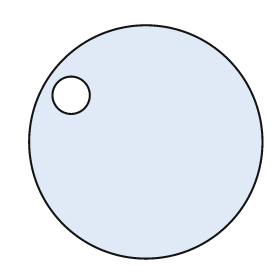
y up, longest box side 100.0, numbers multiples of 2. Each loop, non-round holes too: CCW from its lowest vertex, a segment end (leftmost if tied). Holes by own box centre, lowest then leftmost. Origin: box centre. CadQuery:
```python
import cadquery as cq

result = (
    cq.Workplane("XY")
    .moveTo(0.0, 0.0)
    .circle(50.0)
    .moveTo(-32.0, 20.0)
    .circle(8.0)
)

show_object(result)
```